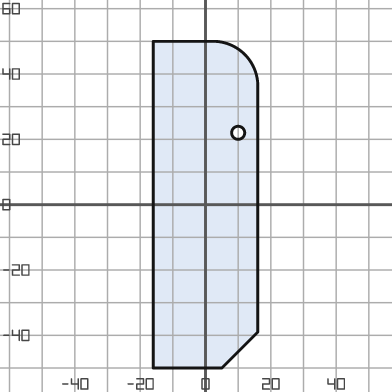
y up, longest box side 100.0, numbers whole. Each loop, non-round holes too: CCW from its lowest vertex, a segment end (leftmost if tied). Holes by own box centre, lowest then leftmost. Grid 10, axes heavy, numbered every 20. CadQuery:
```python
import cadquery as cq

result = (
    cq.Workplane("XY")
    .moveTo(-16.0, -50.0)
    .lineTo(5.0, -50.0)
    .lineTo(16.0, -39.0)
    .lineTo(16.0, 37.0)
    .threePointArc((12.0, 46.0), (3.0, 50.0))
    .lineTo(-16.0, 50.0)
    .close()
    .moveTo(10.0, 22.0)
    .circle(2.0)
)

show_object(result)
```